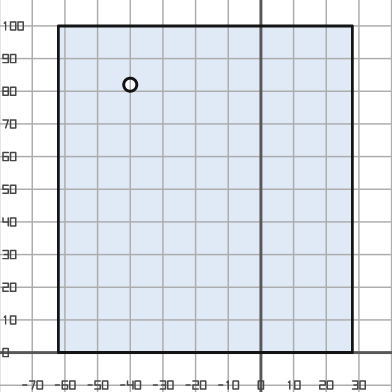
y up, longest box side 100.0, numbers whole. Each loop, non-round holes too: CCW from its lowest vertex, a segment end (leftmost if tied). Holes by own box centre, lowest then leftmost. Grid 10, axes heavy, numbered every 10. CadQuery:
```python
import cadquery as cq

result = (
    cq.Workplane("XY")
    .moveTo(-62.0, 0.0)
    .lineTo(28.0, 0.0)
    .lineTo(28.0, 100.0)
    .lineTo(-62.0, 100.0)
    .close()
    .moveTo(-40.0, 82.0)
    .circle(2.0)
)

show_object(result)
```